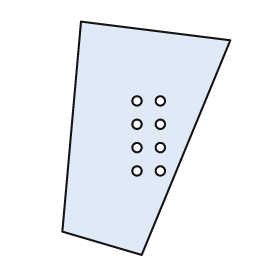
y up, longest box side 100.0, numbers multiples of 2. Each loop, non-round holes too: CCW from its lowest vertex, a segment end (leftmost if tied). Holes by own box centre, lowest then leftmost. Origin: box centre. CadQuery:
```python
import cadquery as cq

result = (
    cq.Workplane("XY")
    .moveTo(-2.0, -50.0)
    .lineTo(36.0, 42.0)
    .lineTo(-28.0, 50.0)
    .lineTo(-36.0, -40.0)
    .close()
    .moveTo(-4.0, -14.0)
    .circle(2.0)
    .moveTo(6.0, -14.0)
    .circle(2.0)
    .moveTo(-4.0, -4.0)
    .circle(2.0)
    .moveTo(6.0, -4.0)
    .circle(2.0)
    .moveTo(-4.0, 6.0)
    .circle(2.0)
    .moveTo(6.0, 6.0)
    .circle(2.0)
    .moveTo(-4.0, 16.0)
    .circle(2.0)
    .moveTo(6.0, 16.0)
    .circle(2.0)
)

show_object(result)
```